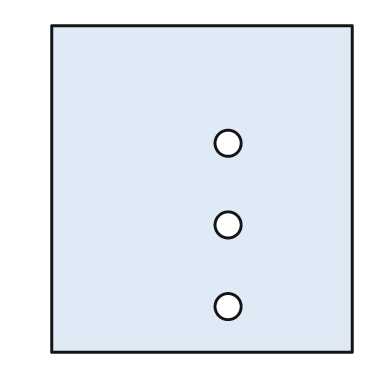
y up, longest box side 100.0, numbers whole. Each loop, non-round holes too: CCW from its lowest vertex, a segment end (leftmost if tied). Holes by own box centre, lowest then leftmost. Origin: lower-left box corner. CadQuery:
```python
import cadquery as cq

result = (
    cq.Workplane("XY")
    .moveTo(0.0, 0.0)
    .lineTo(92.0, 0.0)
    .lineTo(92.0, 100.0)
    .lineTo(0.0, 100.0)
    .close()
    .moveTo(54.0, 14.0)
    .circle(4.0)
    .moveTo(54.0, 39.0)
    .circle(4.0)
    .moveTo(54.0, 64.0)
    .circle(4.0)
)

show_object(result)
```